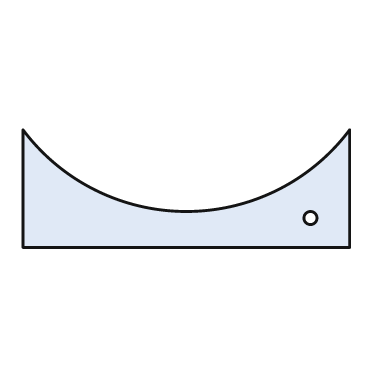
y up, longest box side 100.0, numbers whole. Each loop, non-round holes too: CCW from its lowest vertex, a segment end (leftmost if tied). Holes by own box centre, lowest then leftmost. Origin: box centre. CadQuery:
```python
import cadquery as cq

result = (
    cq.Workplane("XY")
    .moveTo(-50.0, -18.0)
    .lineTo(50.0, -18.0)
    .lineTo(50.0, 18.0)
    .threePointArc((0.0, -7.0), (-50.0, 18.0))
    .close()
    .moveTo(38.0, -9.0)
    .circle(2.0)
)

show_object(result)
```